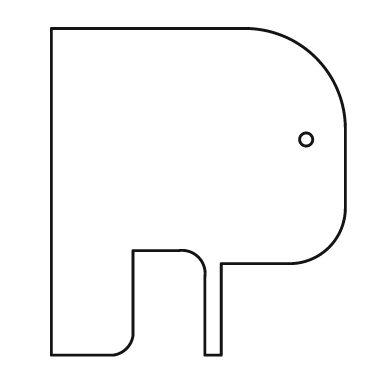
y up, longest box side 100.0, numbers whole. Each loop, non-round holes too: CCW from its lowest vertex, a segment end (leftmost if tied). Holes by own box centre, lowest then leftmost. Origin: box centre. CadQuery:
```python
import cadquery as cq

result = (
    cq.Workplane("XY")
    .moveTo(-45.0, -50.0)
    .lineTo(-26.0, -50.0)
    .threePointArc((-22.0, -48.0), (-20.0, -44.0))
    .lineTo(-20.0, -18.0)
    .lineTo(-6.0, -18.0)
    .threePointArc((0.0, -20.0), (2.0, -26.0))
    .lineTo(2.0, -50.0)
    .lineTo(7.0, -50.0)
    .lineTo(7.0, -22.0)
    .lineTo(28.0, -22.0)
    .threePointArc((40.0, -17.0), (45.0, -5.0))
    .lineTo(45.0, 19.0)
    .threePointArc((36.0, 41.0), (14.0, 50.0))
    .lineTo(-45.0, 50.0)
    .close()
    .moveTo(33.0, 16.0)
    .circle(2.0)
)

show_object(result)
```